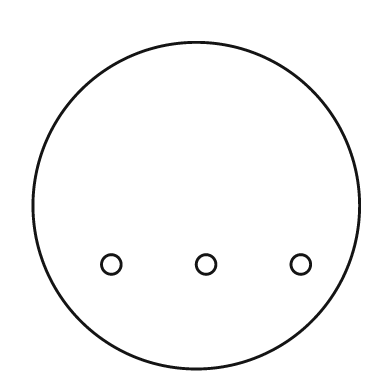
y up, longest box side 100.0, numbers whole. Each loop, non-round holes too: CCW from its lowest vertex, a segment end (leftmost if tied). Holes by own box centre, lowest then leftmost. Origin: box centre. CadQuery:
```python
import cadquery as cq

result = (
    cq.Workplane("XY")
    .moveTo(0.0, 0.0)
    .circle(50.0)
    .moveTo(-26.0, -18.0)
    .circle(3.0)
    .moveTo(3.0, -18.0)
    .circle(3.0)
    .moveTo(32.0, -18.0)
    .circle(3.0)
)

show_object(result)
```